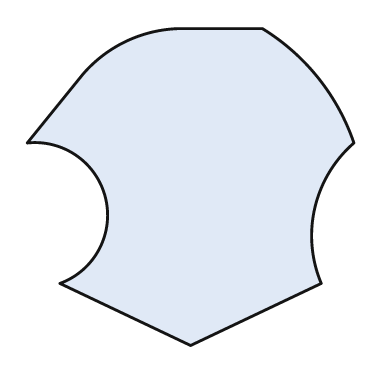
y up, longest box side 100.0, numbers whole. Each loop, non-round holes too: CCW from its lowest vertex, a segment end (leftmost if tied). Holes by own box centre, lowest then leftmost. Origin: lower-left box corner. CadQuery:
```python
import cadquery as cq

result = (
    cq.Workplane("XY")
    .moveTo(50.0, 0.0)
    .lineTo(90.0, 19.0)
    .threePointArc((88.0, 42.0), (100.0, 62.0))
    .threePointArc((89.0, 82.0), (72.0, 97.0))
    .lineTo(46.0, 97.0)
    .threePointArc((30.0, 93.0), (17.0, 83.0))
    .lineTo(0.0, 62.0)
    .threePointArc((24.0, 45.0), (10.0, 19.0))
    .close()
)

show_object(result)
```